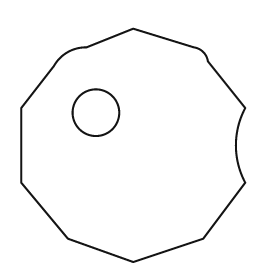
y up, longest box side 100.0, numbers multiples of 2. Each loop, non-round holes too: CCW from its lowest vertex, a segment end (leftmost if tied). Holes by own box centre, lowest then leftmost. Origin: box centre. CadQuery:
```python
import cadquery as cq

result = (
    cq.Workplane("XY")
    .moveTo(0.0, -50.0)
    .lineTo(30.0, -40.0)
    .lineTo(48.0, -16.0)
    .threePointArc((44.0, 0.0), (48.0, 16.0))
    .lineTo(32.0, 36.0)
    .threePointArc((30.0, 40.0), (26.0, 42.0))
    .lineTo(0.0, 50.0)
    .lineTo(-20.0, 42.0)
    .threePointArc((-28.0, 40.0), (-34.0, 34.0))
    .lineTo(-48.0, 16.0)
    .lineTo(-48.0, -16.0)
    .lineTo(-28.0, -40.0)
    .close()
    .moveTo(-16.0, 14.0)
    .circle(10.0)
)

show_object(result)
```